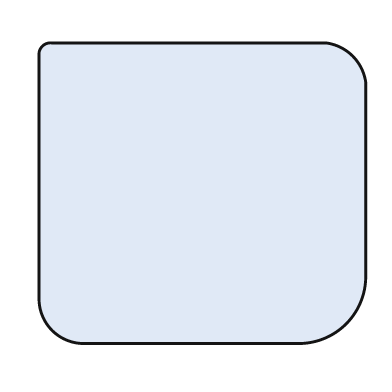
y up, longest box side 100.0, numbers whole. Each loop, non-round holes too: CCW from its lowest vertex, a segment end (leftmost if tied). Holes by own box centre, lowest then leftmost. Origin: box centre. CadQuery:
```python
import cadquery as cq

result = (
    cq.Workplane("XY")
    .moveTo(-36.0, -46.0)
    .lineTo(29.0, -46.0)
    .threePointArc((44.0, -40.0), (50.0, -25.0))
    .lineTo(50.0, 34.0)
    .threePointArc((46.0, 42.0), (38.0, 46.0))
    .lineTo(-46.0, 46.0)
    .threePointArc((-49.0, 45.0), (-50.0, 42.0))
    .lineTo(-50.0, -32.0)
    .threePointArc((-46.0, -42.0), (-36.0, -46.0))
    .close()
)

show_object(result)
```